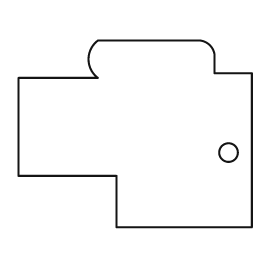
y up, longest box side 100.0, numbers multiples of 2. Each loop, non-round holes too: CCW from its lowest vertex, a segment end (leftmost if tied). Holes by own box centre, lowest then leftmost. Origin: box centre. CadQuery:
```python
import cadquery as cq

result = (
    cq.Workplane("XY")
    .moveTo(-8.0, -40.0)
    .lineTo(50.0, -40.0)
    .lineTo(50.0, 26.0)
    .lineTo(34.0, 26.0)
    .lineTo(34.0, 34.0)
    .threePointArc((32.0, 38.0), (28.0, 40.0))
    .lineTo(-16.0, 40.0)
    .threePointArc((-20.0, 32.0), (-16.0, 24.0))
    .lineTo(-50.0, 24.0)
    .lineTo(-50.0, -18.0)
    .lineTo(-8.0, -18.0)
    .close()
    .moveTo(40.0, -8.0)
    .circle(4.0)
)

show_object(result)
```